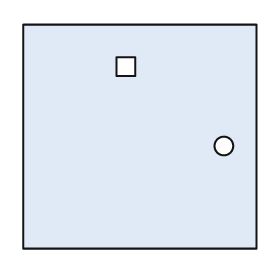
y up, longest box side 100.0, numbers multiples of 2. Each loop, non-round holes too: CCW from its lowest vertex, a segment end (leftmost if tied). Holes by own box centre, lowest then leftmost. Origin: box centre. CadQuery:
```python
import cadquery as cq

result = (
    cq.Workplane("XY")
    .moveTo(-50.0, -48.0)
    .lineTo(50.0, -48.0)
    .lineTo(50.0, 48.0)
    .lineTo(-50.0, 48.0)
    .close()
    .moveTo(36.0, -4.0)
    .circle(4.0)
    .moveTo(-10.0, 26.0)
    .lineTo(-2.0, 26.0)
    .lineTo(-2.0, 34.0)
    .lineTo(-10.0, 34.0)
    .close()
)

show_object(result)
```